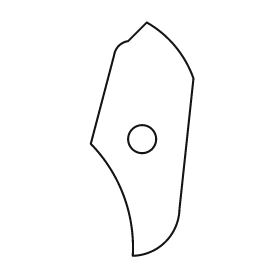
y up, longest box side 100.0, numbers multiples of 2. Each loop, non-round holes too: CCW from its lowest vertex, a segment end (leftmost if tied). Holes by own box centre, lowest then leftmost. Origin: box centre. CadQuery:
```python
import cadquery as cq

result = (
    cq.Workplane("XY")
    .moveTo(-4.0, -50.0)
    .threePointArc((10.0, -44.0), (16.0, -30.0))
    .lineTo(22.0, 26.0)
    .threePointArc((14.0, 40.0), (2.0, 50.0))
    .lineTo(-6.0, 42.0)
    .threePointArc((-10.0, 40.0), (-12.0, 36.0))
    .lineTo(-22.0, -2.0)
    .threePointArc((-8.0, -24.0), (-4.0, -50.0))
    .close()
    .moveTo(0.0, 0.0)
    .circle(6.0)
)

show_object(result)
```